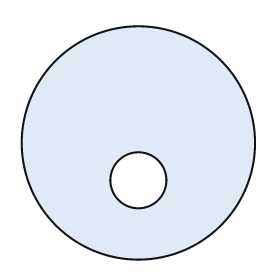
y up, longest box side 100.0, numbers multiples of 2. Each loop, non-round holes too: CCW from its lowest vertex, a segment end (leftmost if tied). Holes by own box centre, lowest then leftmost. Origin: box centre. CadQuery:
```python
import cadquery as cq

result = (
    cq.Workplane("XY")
    .moveTo(0.0, 0.0)
    .circle(50.0)
    .moveTo(0.0, -16.0)
    .circle(12.0)
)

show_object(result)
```